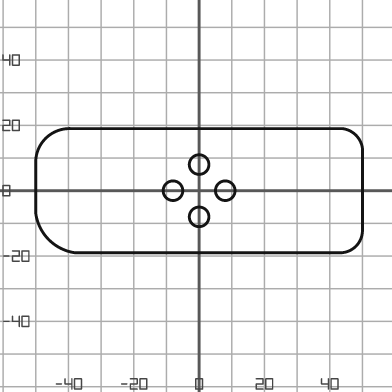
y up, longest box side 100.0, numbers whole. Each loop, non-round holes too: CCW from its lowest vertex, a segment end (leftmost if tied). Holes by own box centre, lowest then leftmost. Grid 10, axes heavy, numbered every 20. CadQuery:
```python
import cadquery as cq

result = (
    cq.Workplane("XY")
    .moveTo(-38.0, -19.0)
    .lineTo(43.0, -19.0)
    .threePointArc((48.0, -17.0), (50.0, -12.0))
    .lineTo(50.0, 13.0)
    .threePointArc((48.0, 17.0), (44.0, 19.0))
    .lineTo(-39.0, 19.0)
    .threePointArc((-47.0, 16.0), (-50.0, 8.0))
    .lineTo(-50.0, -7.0)
    .threePointArc((-46.0, -15.0), (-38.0, -19.0))
    .close()
    .moveTo(0.0, -8.0)
    .circle(3.0)
    .moveTo(-8.0, 0.0)
    .circle(3.0)
    .moveTo(8.0, 0.0)
    .circle(3.0)
    .moveTo(0.0, 8.0)
    .circle(3.0)
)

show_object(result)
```